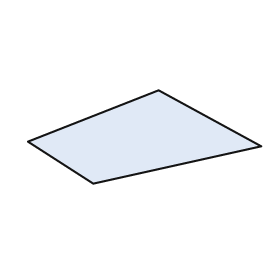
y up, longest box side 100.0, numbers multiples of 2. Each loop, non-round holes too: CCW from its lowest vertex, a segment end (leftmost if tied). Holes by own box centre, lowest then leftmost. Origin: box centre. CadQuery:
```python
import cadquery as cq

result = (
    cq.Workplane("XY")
    .moveTo(-22.0, -20.0)
    .lineTo(50.0, -4.0)
    .lineTo(6.0, 20.0)
    .lineTo(-50.0, -2.0)
    .close()
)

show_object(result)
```